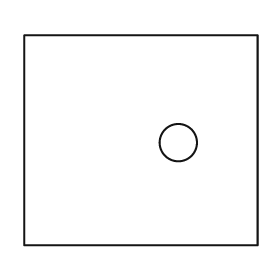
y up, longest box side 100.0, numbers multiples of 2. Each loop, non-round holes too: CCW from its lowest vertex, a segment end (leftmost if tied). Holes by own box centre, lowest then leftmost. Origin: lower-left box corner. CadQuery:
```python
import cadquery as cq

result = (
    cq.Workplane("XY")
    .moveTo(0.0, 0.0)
    .lineTo(100.0, 0.0)
    .lineTo(100.0, 90.0)
    .lineTo(0.0, 90.0)
    .close()
    .moveTo(66.0, 44.0)
    .circle(8.0)
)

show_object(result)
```